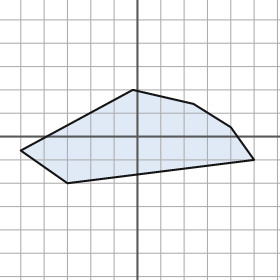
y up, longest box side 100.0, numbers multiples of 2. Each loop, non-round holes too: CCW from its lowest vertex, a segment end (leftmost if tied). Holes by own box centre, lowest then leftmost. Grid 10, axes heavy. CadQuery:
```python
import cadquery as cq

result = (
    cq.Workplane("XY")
    .moveTo(-30.0, -20.0)
    .lineTo(50.0, -10.0)
    .lineTo(40.0, 4.0)
    .lineTo(24.0, 14.0)
    .lineTo(-2.0, 20.0)
    .lineTo(-50.0, -6.0)
    .close()
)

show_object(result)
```